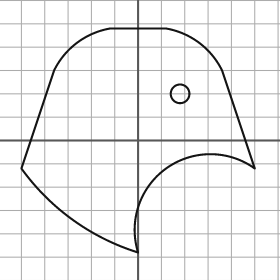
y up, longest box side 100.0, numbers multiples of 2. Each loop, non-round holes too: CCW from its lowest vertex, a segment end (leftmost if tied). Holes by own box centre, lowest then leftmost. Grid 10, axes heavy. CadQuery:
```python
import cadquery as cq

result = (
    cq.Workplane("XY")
    .moveTo(0.0, -48.0)
    .threePointArc((12.0, -12.0), (50.0, -12.0))
    .lineTo(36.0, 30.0)
    .threePointArc((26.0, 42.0), (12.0, 48.0))
    .lineTo(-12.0, 48.0)
    .threePointArc((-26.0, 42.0), (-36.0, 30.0))
    .lineTo(-50.0, -12.0)
    .threePointArc((-28.0, -34.0), (0.0, -48.0))
    .close()
    .moveTo(18.0, 20.0)
    .circle(4.0)
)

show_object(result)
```